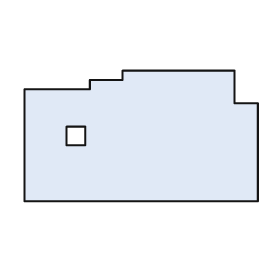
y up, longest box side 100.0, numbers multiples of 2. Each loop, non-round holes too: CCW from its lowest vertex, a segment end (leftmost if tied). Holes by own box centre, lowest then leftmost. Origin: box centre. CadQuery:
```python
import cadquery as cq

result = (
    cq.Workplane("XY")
    .moveTo(-50.0, -28.0)
    .lineTo(50.0, -28.0)
    .lineTo(50.0, 14.0)
    .lineTo(40.0, 14.0)
    .lineTo(40.0, 28.0)
    .lineTo(-8.0, 28.0)
    .lineTo(-8.0, 24.0)
    .lineTo(-22.0, 24.0)
    .lineTo(-22.0, 20.0)
    .lineTo(-50.0, 20.0)
    .close()
    .moveTo(-32.0, -4.0)
    .lineTo(-24.0, -4.0)
    .lineTo(-24.0, 4.0)
    .lineTo(-32.0, 4.0)
    .close()
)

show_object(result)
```